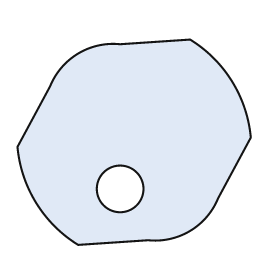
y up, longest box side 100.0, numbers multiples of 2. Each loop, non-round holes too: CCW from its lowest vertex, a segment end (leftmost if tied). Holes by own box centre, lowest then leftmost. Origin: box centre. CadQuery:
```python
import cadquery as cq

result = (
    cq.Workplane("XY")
    .moveTo(-24.0, -44.0)
    .lineTo(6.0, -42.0)
    .threePointArc((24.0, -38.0), (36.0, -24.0))
    .lineTo(50.0, 2.0)
    .threePointArc((42.0, 26.0), (24.0, 44.0))
    .lineTo(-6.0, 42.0)
    .threePointArc((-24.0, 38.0), (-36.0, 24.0))
    .lineTo(-50.0, -2.0)
    .threePointArc((-42.0, -26.0), (-24.0, -44.0))
    .close()
    .moveTo(-6.0, -20.0)
    .circle(10.0)
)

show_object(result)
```